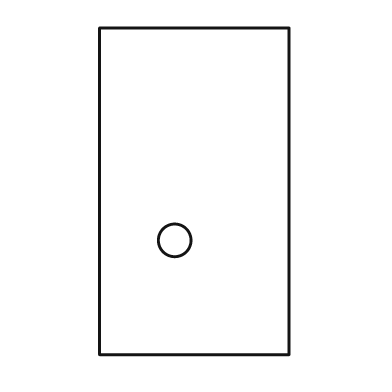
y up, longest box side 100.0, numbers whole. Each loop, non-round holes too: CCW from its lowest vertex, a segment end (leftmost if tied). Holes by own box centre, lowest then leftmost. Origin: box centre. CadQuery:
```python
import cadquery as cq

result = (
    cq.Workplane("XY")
    .moveTo(-29.0, -50.0)
    .lineTo(29.0, -50.0)
    .lineTo(29.0, 50.0)
    .lineTo(-29.0, 50.0)
    .close()
    .moveTo(-6.0, -15.0)
    .circle(5.0)
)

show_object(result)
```